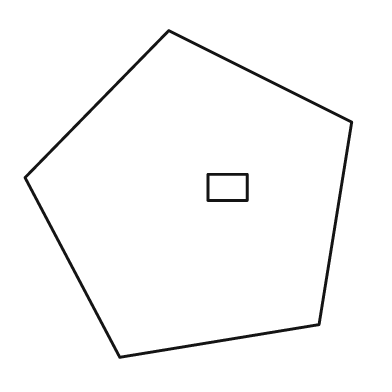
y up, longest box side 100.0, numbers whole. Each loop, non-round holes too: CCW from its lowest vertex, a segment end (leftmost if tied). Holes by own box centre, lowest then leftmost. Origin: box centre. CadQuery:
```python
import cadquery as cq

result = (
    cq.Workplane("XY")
    .moveTo(-21.0, -50.0)
    .lineTo(40.0, -40.0)
    .lineTo(50.0, 22.0)
    .lineTo(-6.0, 50.0)
    .lineTo(-50.0, 5.0)
    .close()
    .moveTo(6.0, -2.0)
    .lineTo(18.0, -2.0)
    .lineTo(18.0, 6.0)
    .lineTo(6.0, 6.0)
    .close()
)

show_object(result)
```